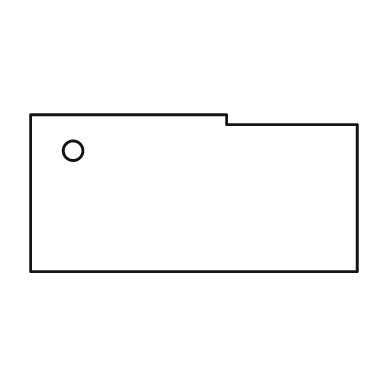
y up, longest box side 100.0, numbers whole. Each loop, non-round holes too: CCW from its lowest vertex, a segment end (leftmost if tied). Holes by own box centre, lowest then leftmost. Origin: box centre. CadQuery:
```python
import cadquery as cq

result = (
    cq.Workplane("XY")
    .moveTo(-50.0, -24.0)
    .lineTo(50.0, -24.0)
    .lineTo(50.0, 21.0)
    .lineTo(10.0, 21.0)
    .lineTo(10.0, 24.0)
    .lineTo(-50.0, 24.0)
    .close()
    .moveTo(-37.0, 13.0)
    .circle(3.0)
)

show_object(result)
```